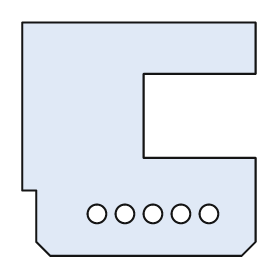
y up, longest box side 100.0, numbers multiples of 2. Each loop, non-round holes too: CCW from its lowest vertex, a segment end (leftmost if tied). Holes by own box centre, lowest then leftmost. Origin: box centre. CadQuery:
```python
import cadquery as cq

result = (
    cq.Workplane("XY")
    .moveTo(-38.0, -50.0)
    .lineTo(44.0, -50.0)
    .lineTo(50.0, -44.0)
    .lineTo(50.0, -8.0)
    .lineTo(2.0, -8.0)
    .lineTo(2.0, 28.0)
    .lineTo(50.0, 28.0)
    .lineTo(50.0, 50.0)
    .lineTo(-50.0, 50.0)
    .lineTo(-50.0, -22.0)
    .lineTo(-44.0, -22.0)
    .lineTo(-44.0, -44.0)
    .close()
    .moveTo(-18.0, -32.0)
    .circle(4.0)
    .moveTo(-6.0, -32.0)
    .circle(4.0)
    .moveTo(6.0, -32.0)
    .circle(4.0)
    .moveTo(18.0, -32.0)
    .circle(4.0)
    .moveTo(30.0, -32.0)
    .circle(4.0)
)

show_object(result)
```